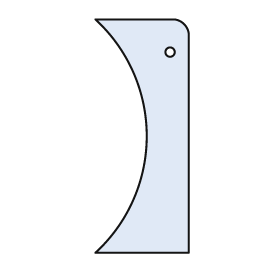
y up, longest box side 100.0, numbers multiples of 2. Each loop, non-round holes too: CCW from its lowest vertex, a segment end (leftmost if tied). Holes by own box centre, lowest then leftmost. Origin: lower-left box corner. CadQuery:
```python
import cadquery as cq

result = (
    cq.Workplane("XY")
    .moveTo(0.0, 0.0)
    .lineTo(40.0, 0.0)
    .lineTo(40.0, 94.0)
    .threePointArc((38.0, 98.0), (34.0, 100.0))
    .lineTo(0.0, 100.0)
    .threePointArc((22.0, 50.0), (0.0, 0.0))
    .close()
    .moveTo(32.0, 86.0)
    .circle(2.0)
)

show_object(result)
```